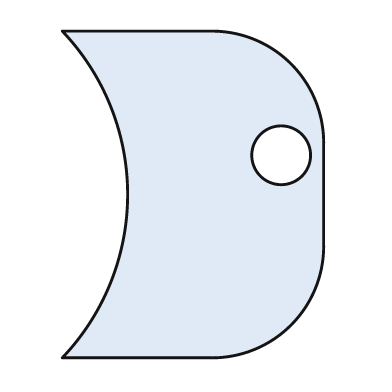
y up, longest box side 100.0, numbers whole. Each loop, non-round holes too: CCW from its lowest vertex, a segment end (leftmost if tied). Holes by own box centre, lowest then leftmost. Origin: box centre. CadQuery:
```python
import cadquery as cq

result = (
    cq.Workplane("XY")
    .moveTo(-40.0, -50.0)
    .lineTo(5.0, -50.0)
    .threePointArc((30.0, -40.0), (40.0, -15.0))
    .lineTo(40.0, 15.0)
    .threePointArc((30.0, 40.0), (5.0, 50.0))
    .lineTo(-40.0, 50.0)
    .threePointArc((-20.0, 0.0), (-40.0, -50.0))
    .close()
    .moveTo(27.0, 12.0)
    .circle(9.0)
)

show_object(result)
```